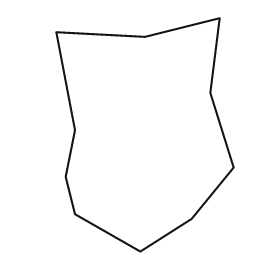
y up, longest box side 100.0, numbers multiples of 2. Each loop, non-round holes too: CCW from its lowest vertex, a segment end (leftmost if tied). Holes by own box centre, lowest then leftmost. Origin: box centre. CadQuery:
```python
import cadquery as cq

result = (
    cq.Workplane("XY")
    .moveTo(-2.0, -50.0)
    .lineTo(20.0, -36.0)
    .lineTo(38.0, -14.0)
    .lineTo(28.0, 18.0)
    .lineTo(32.0, 50.0)
    .lineTo(0.0, 42.0)
    .lineTo(-38.0, 44.0)
    .lineTo(-30.0, 2.0)
    .lineTo(-34.0, -18.0)
    .lineTo(-30.0, -34.0)
    .close()
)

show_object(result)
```